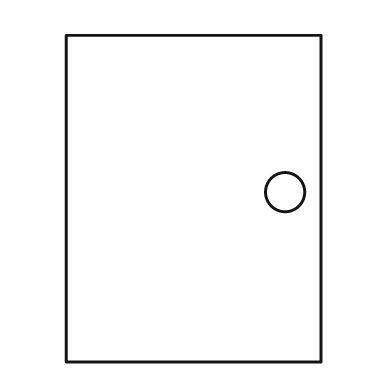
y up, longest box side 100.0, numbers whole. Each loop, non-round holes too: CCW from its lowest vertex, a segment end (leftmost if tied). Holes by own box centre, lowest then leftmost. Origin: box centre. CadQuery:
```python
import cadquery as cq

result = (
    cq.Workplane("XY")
    .moveTo(-39.0, -50.0)
    .lineTo(39.0, -50.0)
    .lineTo(39.0, 50.0)
    .lineTo(-39.0, 50.0)
    .close()
    .moveTo(28.0, 2.0)
    .circle(6.0)
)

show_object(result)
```